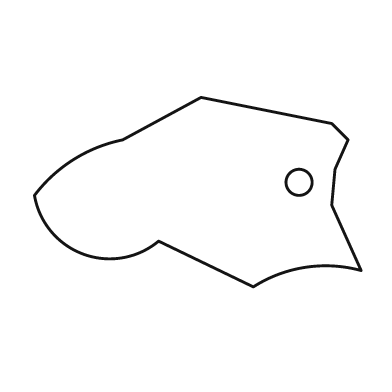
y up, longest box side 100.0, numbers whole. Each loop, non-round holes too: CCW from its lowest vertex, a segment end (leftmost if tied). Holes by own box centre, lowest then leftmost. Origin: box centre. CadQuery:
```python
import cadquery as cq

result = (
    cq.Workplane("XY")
    .moveTo(17.0, -29.0)
    .threePointArc((33.0, -23.0), (50.0, -24.0))
    .lineTo(41.0, -4.0)
    .lineTo(42.0, 7.0)
    .lineTo(46.0, 16.0)
    .lineTo(41.0, 21.0)
    .lineTo(1.0, 29.0)
    .lineTo(-23.0, 16.0)
    .threePointArc((-38.0, 10.0), (-50.0, -1.0))
    .threePointArc((-35.0, -19.0), (-12.0, -15.0))
    .close()
    .moveTo(31.0, 3.0)
    .circle(4.0)
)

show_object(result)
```